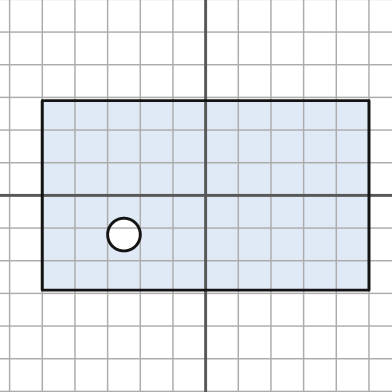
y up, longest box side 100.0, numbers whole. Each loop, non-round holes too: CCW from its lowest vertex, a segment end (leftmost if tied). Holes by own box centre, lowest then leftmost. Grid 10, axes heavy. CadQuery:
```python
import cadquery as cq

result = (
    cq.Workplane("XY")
    .moveTo(-50.0, -29.0)
    .lineTo(50.0, -29.0)
    .lineTo(50.0, 29.0)
    .lineTo(-50.0, 29.0)
    .close()
    .moveTo(-25.0, -12.0)
    .circle(5.0)
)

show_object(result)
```